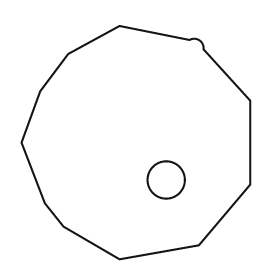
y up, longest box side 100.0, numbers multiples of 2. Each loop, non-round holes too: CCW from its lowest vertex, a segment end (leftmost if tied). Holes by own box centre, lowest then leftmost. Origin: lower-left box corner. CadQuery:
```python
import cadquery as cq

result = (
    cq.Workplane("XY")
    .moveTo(42.0, 0.0)
    .lineTo(76.0, 6.0)
    .lineTo(98.0, 32.0)
    .lineTo(98.0, 68.0)
    .lineTo(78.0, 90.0)
    .threePointArc((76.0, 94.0), (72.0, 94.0))
    .lineTo(42.0, 100.0)
    .lineTo(20.0, 88.0)
    .lineTo(8.0, 72.0)
    .lineTo(0.0, 50.0)
    .lineTo(10.0, 24.0)
    .lineTo(18.0, 14.0)
    .close()
    .moveTo(62.0, 34.0)
    .circle(8.0)
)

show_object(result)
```